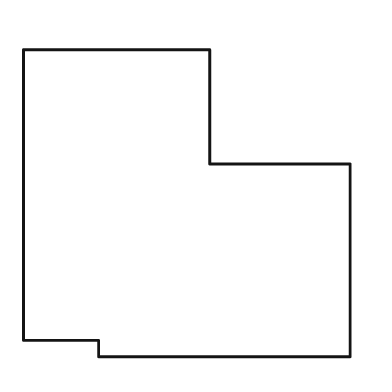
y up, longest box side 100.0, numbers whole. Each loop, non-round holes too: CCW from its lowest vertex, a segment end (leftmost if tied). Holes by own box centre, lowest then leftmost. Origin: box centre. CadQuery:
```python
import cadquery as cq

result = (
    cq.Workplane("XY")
    .moveTo(-27.0, -47.0)
    .lineTo(50.0, -47.0)
    .lineTo(50.0, 12.0)
    .lineTo(7.0, 12.0)
    .lineTo(7.0, 47.0)
    .lineTo(-50.0, 47.0)
    .lineTo(-50.0, -42.0)
    .lineTo(-27.0, -42.0)
    .close()
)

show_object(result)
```